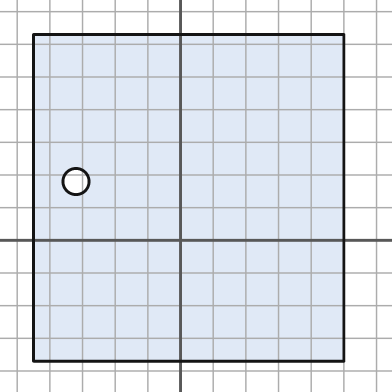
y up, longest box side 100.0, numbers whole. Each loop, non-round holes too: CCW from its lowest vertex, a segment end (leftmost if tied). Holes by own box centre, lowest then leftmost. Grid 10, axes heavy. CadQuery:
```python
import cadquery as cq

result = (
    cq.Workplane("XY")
    .moveTo(-45.0, -37.0)
    .lineTo(50.0, -37.0)
    .lineTo(50.0, 63.0)
    .lineTo(-45.0, 63.0)
    .close()
    .moveTo(-32.0, 18.0)
    .circle(4.0)
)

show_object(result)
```